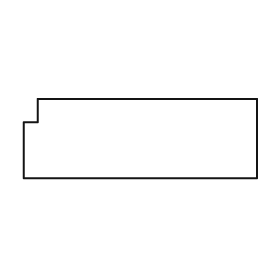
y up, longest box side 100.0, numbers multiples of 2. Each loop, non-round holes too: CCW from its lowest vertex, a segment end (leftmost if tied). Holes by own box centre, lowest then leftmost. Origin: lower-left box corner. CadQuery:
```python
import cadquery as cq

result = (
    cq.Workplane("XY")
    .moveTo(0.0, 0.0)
    .lineTo(100.0, 0.0)
    .lineTo(100.0, 34.0)
    .lineTo(6.0, 34.0)
    .lineTo(6.0, 24.0)
    .lineTo(0.0, 24.0)
    .close()
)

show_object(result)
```